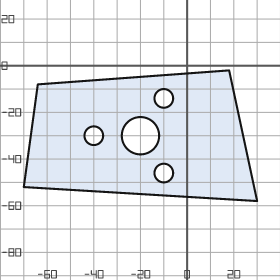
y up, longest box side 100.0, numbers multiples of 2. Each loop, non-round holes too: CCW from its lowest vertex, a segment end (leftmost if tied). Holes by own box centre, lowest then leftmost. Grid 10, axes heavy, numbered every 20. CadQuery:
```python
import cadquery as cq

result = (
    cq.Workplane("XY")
    .moveTo(30.0, -58.0)
    .lineTo(18.0, -2.0)
    .lineTo(-64.0, -8.0)
    .lineTo(-70.0, -52.0)
    .close()
    .moveTo(-10.0, -46.0)
    .circle(4.0)
    .moveTo(-40.0, -30.0)
    .circle(4.0)
    .moveTo(-20.0, -30.0)
    .circle(8.0)
    .moveTo(-10.0, -14.0)
    .circle(4.0)
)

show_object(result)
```